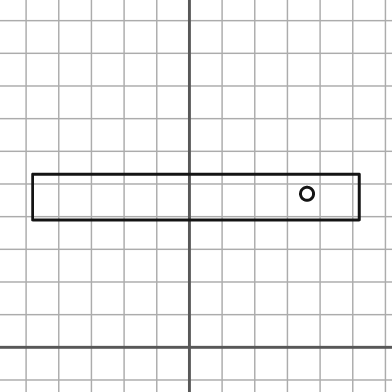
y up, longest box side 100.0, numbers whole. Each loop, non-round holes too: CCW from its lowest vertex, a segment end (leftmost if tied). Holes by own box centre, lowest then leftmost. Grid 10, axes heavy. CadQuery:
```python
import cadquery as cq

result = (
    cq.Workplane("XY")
    .moveTo(-48.0, 39.0)
    .lineTo(52.0, 39.0)
    .lineTo(52.0, 53.0)
    .lineTo(-48.0, 53.0)
    .close()
    .moveTo(36.0, 47.0)
    .circle(2.0)
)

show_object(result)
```